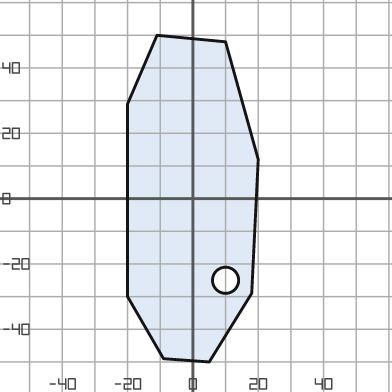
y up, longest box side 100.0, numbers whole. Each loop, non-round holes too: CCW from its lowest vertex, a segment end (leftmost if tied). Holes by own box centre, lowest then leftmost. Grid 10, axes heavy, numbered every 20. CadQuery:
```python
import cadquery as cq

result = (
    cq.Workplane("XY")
    .moveTo(5.0, -50.0)
    .lineTo(18.0, -29.0)
    .lineTo(20.0, 12.0)
    .lineTo(10.0, 48.0)
    .lineTo(-11.0, 50.0)
    .lineTo(-20.0, 29.0)
    .lineTo(-20.0, -30.0)
    .lineTo(-9.0, -49.0)
    .close()
    .moveTo(10.0, -25.0)
    .circle(4.0)
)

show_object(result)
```